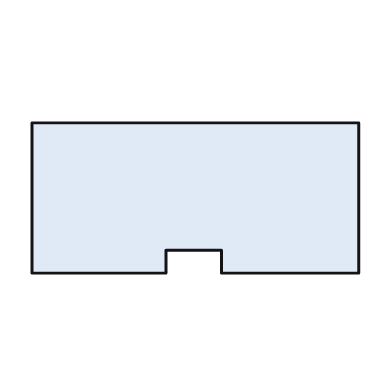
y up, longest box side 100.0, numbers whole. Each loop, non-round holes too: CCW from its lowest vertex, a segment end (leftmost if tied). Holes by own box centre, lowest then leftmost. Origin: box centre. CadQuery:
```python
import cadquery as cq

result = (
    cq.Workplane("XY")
    .moveTo(-50.0, -23.0)
    .lineTo(-9.0, -23.0)
    .lineTo(-9.0, -16.0)
    .lineTo(8.0, -16.0)
    .lineTo(8.0, -23.0)
    .lineTo(50.0, -23.0)
    .lineTo(50.0, 23.0)
    .lineTo(-50.0, 23.0)
    .close()
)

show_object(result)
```